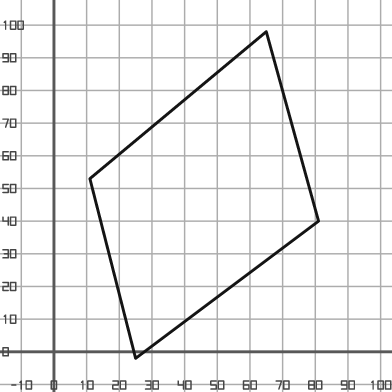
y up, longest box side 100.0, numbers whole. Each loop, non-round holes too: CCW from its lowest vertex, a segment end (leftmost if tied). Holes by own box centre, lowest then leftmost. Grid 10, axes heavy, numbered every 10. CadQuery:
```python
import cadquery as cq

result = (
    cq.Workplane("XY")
    .moveTo(25.0, -2.0)
    .lineTo(81.0, 40.0)
    .lineTo(65.0, 98.0)
    .lineTo(11.0, 53.0)
    .close()
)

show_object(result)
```